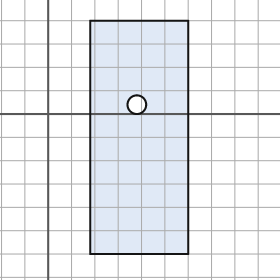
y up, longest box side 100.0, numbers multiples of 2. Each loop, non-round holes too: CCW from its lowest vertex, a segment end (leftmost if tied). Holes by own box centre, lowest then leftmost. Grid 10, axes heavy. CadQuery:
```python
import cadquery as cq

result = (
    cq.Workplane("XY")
    .moveTo(18.0, -60.0)
    .lineTo(60.0, -60.0)
    .lineTo(60.0, 40.0)
    .lineTo(18.0, 40.0)
    .close()
    .moveTo(38.0, 4.0)
    .circle(4.0)
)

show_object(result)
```